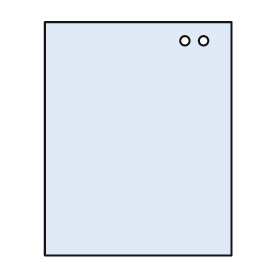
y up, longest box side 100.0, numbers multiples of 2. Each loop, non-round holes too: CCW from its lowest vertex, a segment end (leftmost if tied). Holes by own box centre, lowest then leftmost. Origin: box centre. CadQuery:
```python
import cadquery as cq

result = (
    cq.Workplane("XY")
    .moveTo(-40.0, -50.0)
    .lineTo(40.0, -50.0)
    .lineTo(40.0, 50.0)
    .lineTo(-40.0, 50.0)
    .close()
    .moveTo(20.0, 42.0)
    .circle(2.0)
    .moveTo(28.0, 42.0)
    .circle(2.0)
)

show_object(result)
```